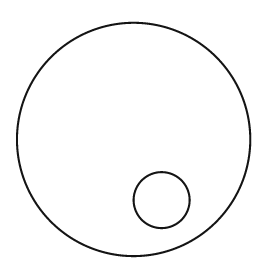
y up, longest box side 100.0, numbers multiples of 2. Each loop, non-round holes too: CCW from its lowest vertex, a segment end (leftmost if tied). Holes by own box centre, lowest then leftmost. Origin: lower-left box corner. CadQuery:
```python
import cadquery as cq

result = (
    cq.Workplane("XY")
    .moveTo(50.0, 50.0)
    .circle(50.0)
    .moveTo(62.0, 24.0)
    .circle(12.0)
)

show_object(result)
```